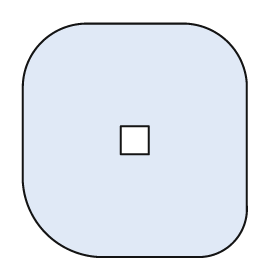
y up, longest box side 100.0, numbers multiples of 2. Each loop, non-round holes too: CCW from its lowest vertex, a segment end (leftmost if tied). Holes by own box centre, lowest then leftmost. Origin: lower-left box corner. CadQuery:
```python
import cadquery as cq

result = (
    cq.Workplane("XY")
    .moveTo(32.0, 0.0)
    .lineTo(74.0, 0.0)
    .threePointArc((90.0, 6.0), (96.0, 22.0))
    .lineTo(96.0, 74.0)
    .threePointArc((88.0, 92.0), (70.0, 100.0))
    .lineTo(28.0, 100.0)
    .threePointArc((8.0, 92.0), (0.0, 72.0))
    .lineTo(0.0, 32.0)
    .threePointArc((10.0, 10.0), (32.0, 0.0))
    .close()
    .moveTo(42.0, 44.0)
    .lineTo(54.0, 44.0)
    .lineTo(54.0, 56.0)
    .lineTo(42.0, 56.0)
    .close()
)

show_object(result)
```